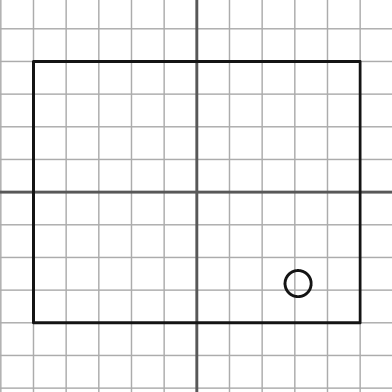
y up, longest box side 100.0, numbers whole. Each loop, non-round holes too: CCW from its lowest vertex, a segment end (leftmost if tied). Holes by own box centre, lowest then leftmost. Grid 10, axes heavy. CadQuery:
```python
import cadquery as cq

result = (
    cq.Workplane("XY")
    .moveTo(-50.0, -40.0)
    .lineTo(50.0, -40.0)
    .lineTo(50.0, 40.0)
    .lineTo(-50.0, 40.0)
    .close()
    .moveTo(31.0, -28.0)
    .circle(4.0)
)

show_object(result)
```